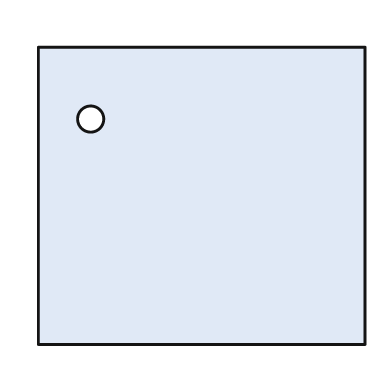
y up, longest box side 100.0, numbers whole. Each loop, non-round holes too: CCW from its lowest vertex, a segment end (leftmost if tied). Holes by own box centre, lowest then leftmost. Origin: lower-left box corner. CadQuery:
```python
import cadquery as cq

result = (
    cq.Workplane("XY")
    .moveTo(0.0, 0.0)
    .lineTo(100.0, 0.0)
    .lineTo(100.0, 91.0)
    .lineTo(0.0, 91.0)
    .close()
    .moveTo(16.0, 69.0)
    .circle(4.0)
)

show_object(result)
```